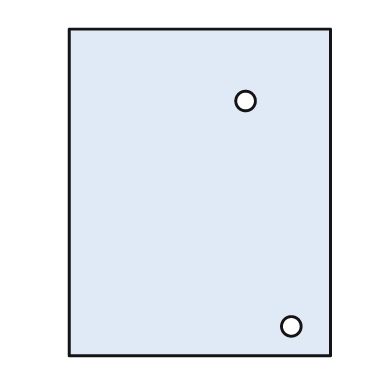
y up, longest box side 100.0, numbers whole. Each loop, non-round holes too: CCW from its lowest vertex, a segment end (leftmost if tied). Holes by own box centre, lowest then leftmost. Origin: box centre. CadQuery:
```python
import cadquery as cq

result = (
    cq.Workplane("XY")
    .moveTo(-40.0, -50.0)
    .lineTo(40.0, -50.0)
    .lineTo(40.0, 50.0)
    .lineTo(-40.0, 50.0)
    .close()
    .moveTo(28.0, -41.0)
    .circle(3.0)
    .moveTo(14.0, 28.0)
    .circle(3.0)
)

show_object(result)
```